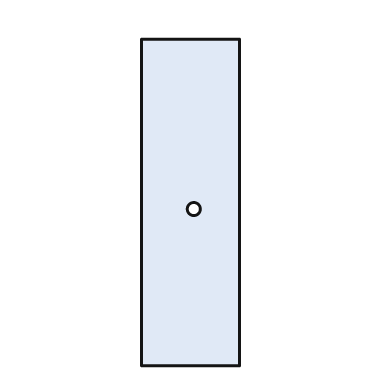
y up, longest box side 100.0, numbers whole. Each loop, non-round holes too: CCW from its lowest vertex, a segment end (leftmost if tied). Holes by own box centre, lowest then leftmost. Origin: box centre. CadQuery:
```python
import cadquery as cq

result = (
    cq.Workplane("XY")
    .moveTo(-15.0, -50.0)
    .lineTo(15.0, -50.0)
    .lineTo(15.0, 50.0)
    .lineTo(-15.0, 50.0)
    .close()
    .moveTo(1.0, -2.0)
    .circle(2.0)
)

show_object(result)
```